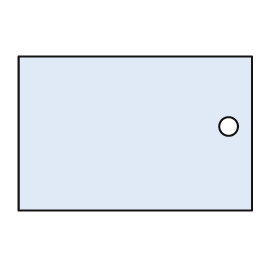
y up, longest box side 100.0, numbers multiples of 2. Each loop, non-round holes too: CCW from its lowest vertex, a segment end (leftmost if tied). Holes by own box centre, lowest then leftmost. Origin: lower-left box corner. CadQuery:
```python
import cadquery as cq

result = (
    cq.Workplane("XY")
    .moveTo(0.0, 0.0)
    .lineTo(100.0, 0.0)
    .lineTo(100.0, 66.0)
    .lineTo(0.0, 66.0)
    .close()
    .moveTo(90.0, 36.0)
    .circle(4.0)
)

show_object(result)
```